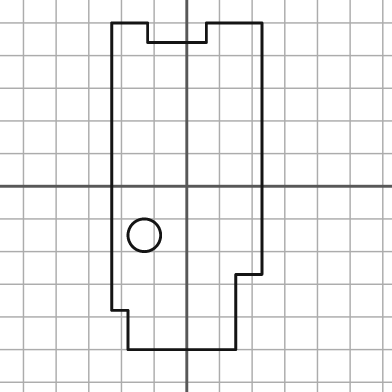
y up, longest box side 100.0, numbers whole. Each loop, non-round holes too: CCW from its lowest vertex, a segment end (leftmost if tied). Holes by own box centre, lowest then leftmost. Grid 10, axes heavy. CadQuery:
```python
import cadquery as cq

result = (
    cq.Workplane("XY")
    .moveTo(-18.0, -50.0)
    .lineTo(15.0, -50.0)
    .lineTo(15.0, -27.0)
    .lineTo(23.0, -27.0)
    .lineTo(23.0, 50.0)
    .lineTo(6.0, 50.0)
    .lineTo(6.0, 44.0)
    .lineTo(-12.0, 44.0)
    .lineTo(-12.0, 50.0)
    .lineTo(-23.0, 50.0)
    .lineTo(-23.0, -38.0)
    .lineTo(-18.0, -38.0)
    .close()
    .moveTo(-13.0, -15.0)
    .circle(5.0)
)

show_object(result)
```